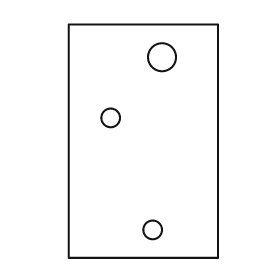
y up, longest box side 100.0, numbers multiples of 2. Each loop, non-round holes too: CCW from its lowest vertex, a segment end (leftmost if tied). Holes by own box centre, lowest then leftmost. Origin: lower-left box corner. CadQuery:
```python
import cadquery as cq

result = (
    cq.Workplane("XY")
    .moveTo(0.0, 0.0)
    .lineTo(64.0, 0.0)
    .lineTo(64.0, 100.0)
    .lineTo(0.0, 100.0)
    .close()
    .moveTo(36.0, 12.0)
    .circle(4.0)
    .moveTo(18.0, 60.0)
    .circle(4.0)
    .moveTo(40.0, 86.0)
    .circle(6.0)
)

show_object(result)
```